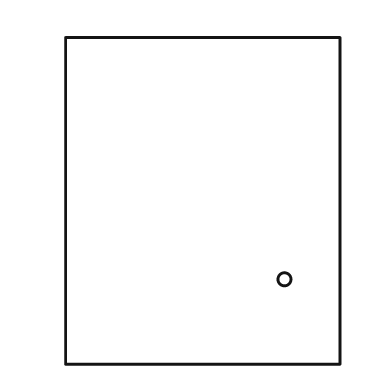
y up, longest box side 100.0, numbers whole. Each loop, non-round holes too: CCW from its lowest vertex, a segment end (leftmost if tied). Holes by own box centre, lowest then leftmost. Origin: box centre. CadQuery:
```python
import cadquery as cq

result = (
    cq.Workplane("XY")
    .moveTo(-42.0, -50.0)
    .lineTo(42.0, -50.0)
    .lineTo(42.0, 50.0)
    .lineTo(-42.0, 50.0)
    .close()
    .moveTo(25.0, -24.0)
    .circle(2.0)
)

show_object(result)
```